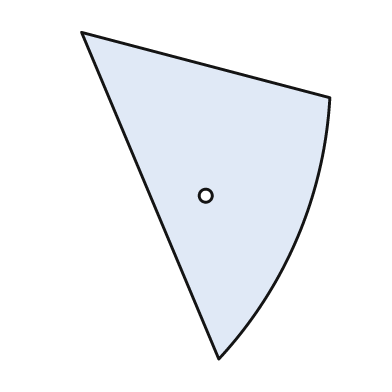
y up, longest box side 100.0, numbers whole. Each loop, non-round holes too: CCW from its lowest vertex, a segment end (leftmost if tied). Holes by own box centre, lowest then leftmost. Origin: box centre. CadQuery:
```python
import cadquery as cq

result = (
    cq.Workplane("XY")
    .moveTo(4.0, -50.0)
    .threePointArc((28.0, -13.0), (38.0, 30.0))
    .lineTo(-38.0, 50.0)
    .close()
    .moveTo(0.0, 0.0)
    .circle(2.0)
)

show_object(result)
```